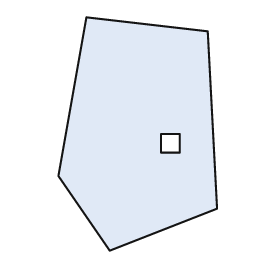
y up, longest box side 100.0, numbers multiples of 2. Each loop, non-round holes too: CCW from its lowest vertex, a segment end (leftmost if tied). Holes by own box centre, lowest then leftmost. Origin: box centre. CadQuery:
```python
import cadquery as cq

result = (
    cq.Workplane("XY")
    .moveTo(-12.0, -50.0)
    .lineTo(34.0, -32.0)
    .lineTo(30.0, 44.0)
    .lineTo(-22.0, 50.0)
    .lineTo(-34.0, -18.0)
    .close()
    .moveTo(10.0, -8.0)
    .lineTo(18.0, -8.0)
    .lineTo(18.0, 0.0)
    .lineTo(10.0, 0.0)
    .close()
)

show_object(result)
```